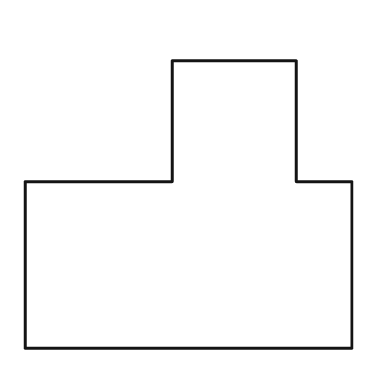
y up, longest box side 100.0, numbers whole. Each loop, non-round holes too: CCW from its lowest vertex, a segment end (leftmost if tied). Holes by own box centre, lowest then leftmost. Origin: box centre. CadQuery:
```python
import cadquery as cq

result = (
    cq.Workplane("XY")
    .moveTo(-50.0, -44.0)
    .lineTo(50.0, -44.0)
    .lineTo(50.0, 7.0)
    .lineTo(33.0, 7.0)
    .lineTo(33.0, 44.0)
    .lineTo(-5.0, 44.0)
    .lineTo(-5.0, 7.0)
    .lineTo(-50.0, 7.0)
    .close()
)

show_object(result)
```